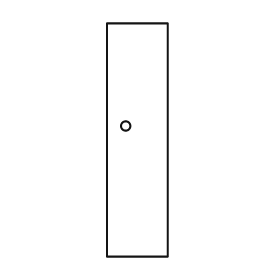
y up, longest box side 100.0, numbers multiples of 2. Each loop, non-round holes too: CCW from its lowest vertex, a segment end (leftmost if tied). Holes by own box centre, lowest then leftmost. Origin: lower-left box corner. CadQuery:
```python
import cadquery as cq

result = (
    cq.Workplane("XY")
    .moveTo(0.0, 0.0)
    .lineTo(26.0, 0.0)
    .lineTo(26.0, 100.0)
    .lineTo(0.0, 100.0)
    .close()
    .moveTo(8.0, 56.0)
    .circle(2.0)
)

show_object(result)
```